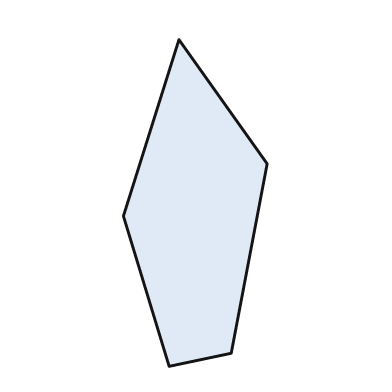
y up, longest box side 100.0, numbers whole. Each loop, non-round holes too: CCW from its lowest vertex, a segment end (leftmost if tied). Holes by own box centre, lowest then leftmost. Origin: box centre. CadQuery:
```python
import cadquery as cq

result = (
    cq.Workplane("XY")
    .moveTo(-8.0, -50.0)
    .lineTo(11.0, -46.0)
    .lineTo(22.0, 12.0)
    .lineTo(-5.0, 50.0)
    .lineTo(-22.0, -4.0)
    .close()
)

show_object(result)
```